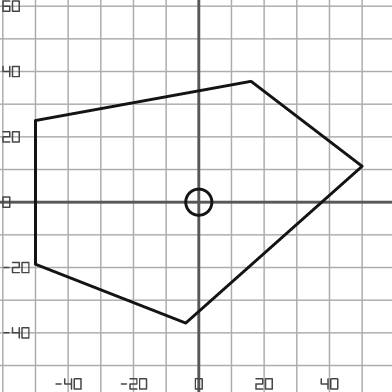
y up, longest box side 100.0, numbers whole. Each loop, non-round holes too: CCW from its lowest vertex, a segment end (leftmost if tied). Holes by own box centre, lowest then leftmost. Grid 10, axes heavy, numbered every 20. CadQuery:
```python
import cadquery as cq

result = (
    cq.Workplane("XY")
    .moveTo(-4.0, -37.0)
    .lineTo(50.0, 11.0)
    .lineTo(16.0, 37.0)
    .lineTo(-50.0, 25.0)
    .lineTo(-50.0, -19.0)
    .close()
    .moveTo(0.0, 0.0)
    .circle(4.0)
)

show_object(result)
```